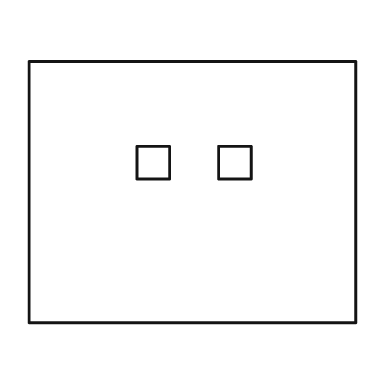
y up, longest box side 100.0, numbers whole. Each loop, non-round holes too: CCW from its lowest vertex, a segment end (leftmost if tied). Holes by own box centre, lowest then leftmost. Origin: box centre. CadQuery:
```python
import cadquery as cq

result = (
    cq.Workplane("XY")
    .moveTo(-50.0, -40.0)
    .lineTo(50.0, -40.0)
    .lineTo(50.0, 40.0)
    .lineTo(-50.0, 40.0)
    .close()
    .moveTo(-17.0, 4.0)
    .lineTo(-7.0, 4.0)
    .lineTo(-7.0, 14.0)
    .lineTo(-17.0, 14.0)
    .close()
    .moveTo(8.0, 4.0)
    .lineTo(18.0, 4.0)
    .lineTo(18.0, 14.0)
    .lineTo(8.0, 14.0)
    .close()
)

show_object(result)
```